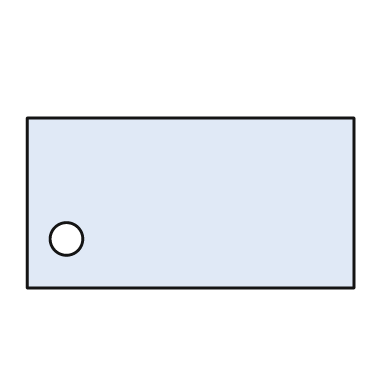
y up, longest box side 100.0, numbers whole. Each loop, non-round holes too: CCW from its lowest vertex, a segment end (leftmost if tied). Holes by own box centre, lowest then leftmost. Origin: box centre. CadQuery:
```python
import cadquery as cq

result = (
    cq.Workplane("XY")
    .moveTo(-50.0, -26.0)
    .lineTo(50.0, -26.0)
    .lineTo(50.0, 26.0)
    .lineTo(-50.0, 26.0)
    .close()
    .moveTo(-38.0, -11.0)
    .circle(5.0)
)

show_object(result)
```